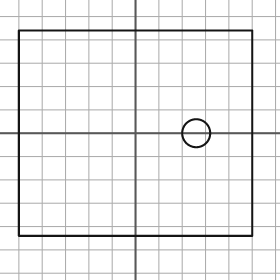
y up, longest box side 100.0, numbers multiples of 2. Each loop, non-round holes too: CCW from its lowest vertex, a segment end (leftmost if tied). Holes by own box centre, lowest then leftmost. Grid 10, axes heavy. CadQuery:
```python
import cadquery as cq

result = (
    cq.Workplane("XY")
    .moveTo(-50.0, -44.0)
    .lineTo(50.0, -44.0)
    .lineTo(50.0, 44.0)
    .lineTo(-50.0, 44.0)
    .close()
    .moveTo(26.0, 0.0)
    .circle(6.0)
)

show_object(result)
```